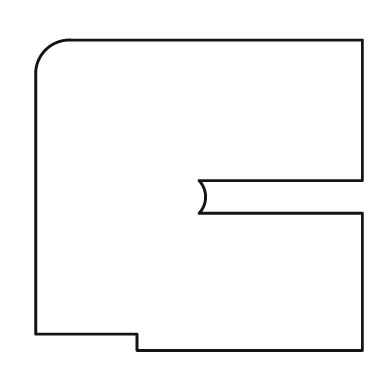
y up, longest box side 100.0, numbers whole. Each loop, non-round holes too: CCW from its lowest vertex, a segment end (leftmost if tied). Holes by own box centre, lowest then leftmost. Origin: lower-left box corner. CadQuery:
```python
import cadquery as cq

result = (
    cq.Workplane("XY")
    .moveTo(31.0, 0.0)
    .lineTo(100.0, 0.0)
    .lineTo(100.0, 42.0)
    .lineTo(50.0, 42.0)
    .threePointArc((52.0, 47.0), (50.0, 52.0))
    .lineTo(100.0, 52.0)
    .lineTo(100.0, 95.0)
    .lineTo(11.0, 95.0)
    .threePointArc((3.0, 92.0), (0.0, 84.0))
    .lineTo(0.0, 5.0)
    .lineTo(31.0, 5.0)
    .close()
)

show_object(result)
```